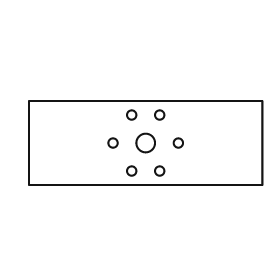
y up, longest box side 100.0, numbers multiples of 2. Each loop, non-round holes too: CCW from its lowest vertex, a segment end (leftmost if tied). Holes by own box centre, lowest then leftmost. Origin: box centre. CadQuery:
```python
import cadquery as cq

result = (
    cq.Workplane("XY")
    .moveTo(-50.0, -18.0)
    .lineTo(50.0, -18.0)
    .lineTo(50.0, 18.0)
    .lineTo(-50.0, 18.0)
    .close()
    .moveTo(-6.0, -12.0)
    .circle(2.0)
    .moveTo(6.0, -12.0)
    .circle(2.0)
    .moveTo(-14.0, 0.0)
    .circle(2.0)
    .moveTo(0.0, 0.0)
    .circle(4.0)
    .moveTo(14.0, 0.0)
    .circle(2.0)
    .moveTo(-6.0, 12.0)
    .circle(2.0)
    .moveTo(6.0, 12.0)
    .circle(2.0)
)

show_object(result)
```